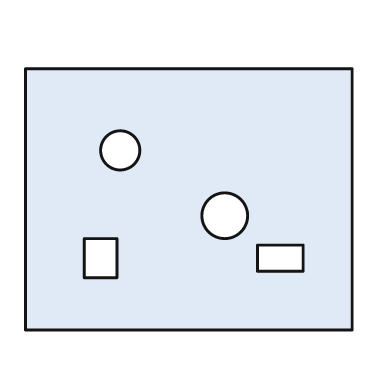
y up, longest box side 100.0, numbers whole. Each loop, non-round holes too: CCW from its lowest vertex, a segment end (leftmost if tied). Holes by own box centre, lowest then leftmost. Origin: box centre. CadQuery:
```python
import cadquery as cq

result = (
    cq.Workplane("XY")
    .moveTo(-50.0, -40.0)
    .lineTo(50.0, -40.0)
    .lineTo(50.0, 40.0)
    .lineTo(-50.0, 40.0)
    .close()
    .moveTo(-32.0, -24.0)
    .lineTo(-22.0, -24.0)
    .lineTo(-22.0, -12.0)
    .lineTo(-32.0, -12.0)
    .close()
    .moveTo(21.0, -22.0)
    .lineTo(35.0, -22.0)
    .lineTo(35.0, -14.0)
    .lineTo(21.0, -14.0)
    .close()
    .moveTo(11.0, -5.0)
    .circle(7.0)
    .moveTo(-21.0, 15.0)
    .circle(6.0)
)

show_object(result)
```